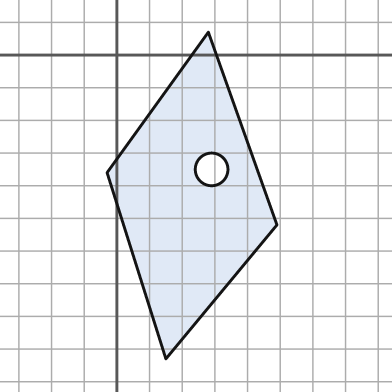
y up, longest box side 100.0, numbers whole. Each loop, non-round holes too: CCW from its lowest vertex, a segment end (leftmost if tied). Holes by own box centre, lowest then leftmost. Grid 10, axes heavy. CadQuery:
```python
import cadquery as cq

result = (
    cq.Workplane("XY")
    .moveTo(15.0, -93.0)
    .lineTo(49.0, -52.0)
    .lineTo(28.0, 7.0)
    .lineTo(-3.0, -36.0)
    .close()
    .moveTo(29.0, -35.0)
    .circle(5.0)
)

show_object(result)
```